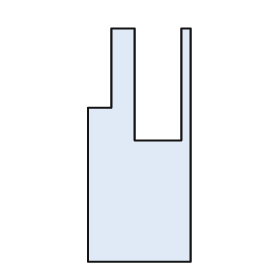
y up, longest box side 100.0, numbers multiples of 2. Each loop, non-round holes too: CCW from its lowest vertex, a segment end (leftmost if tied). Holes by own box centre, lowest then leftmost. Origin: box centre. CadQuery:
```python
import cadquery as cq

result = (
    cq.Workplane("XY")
    .moveTo(-22.0, -50.0)
    .lineTo(22.0, -50.0)
    .lineTo(22.0, 50.0)
    .lineTo(18.0, 50.0)
    .lineTo(18.0, 2.0)
    .lineTo(-2.0, 2.0)
    .lineTo(-2.0, 50.0)
    .lineTo(-12.0, 50.0)
    .lineTo(-12.0, 16.0)
    .lineTo(-22.0, 16.0)
    .close()
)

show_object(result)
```